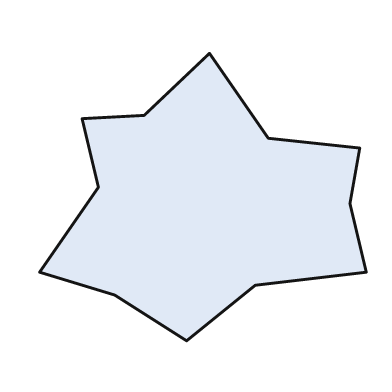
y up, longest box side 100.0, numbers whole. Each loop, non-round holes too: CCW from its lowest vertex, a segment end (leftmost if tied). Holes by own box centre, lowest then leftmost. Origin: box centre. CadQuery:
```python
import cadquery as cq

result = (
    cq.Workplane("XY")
    .moveTo(-5.0, -44.0)
    .lineTo(16.0, -27.0)
    .lineTo(50.0, -23.0)
    .lineTo(45.0, -2.0)
    .lineTo(48.0, 15.0)
    .lineTo(20.0, 18.0)
    .lineTo(2.0, 44.0)
    .lineTo(-18.0, 25.0)
    .lineTo(-37.0, 24.0)
    .lineTo(-32.0, 3.0)
    .lineTo(-50.0, -23.0)
    .lineTo(-27.0, -30.0)
    .close()
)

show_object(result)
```